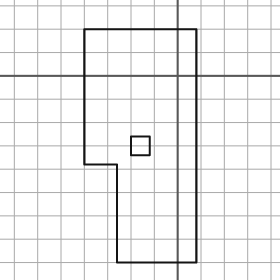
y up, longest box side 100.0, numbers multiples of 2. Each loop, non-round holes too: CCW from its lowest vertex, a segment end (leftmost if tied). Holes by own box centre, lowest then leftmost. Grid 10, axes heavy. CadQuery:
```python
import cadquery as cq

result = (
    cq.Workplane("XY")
    .moveTo(-26.0, -80.0)
    .lineTo(8.0, -80.0)
    .lineTo(8.0, 20.0)
    .lineTo(-40.0, 20.0)
    .lineTo(-40.0, -38.0)
    .lineTo(-26.0, -38.0)
    .close()
    .moveTo(-20.0, -34.0)
    .lineTo(-12.0, -34.0)
    .lineTo(-12.0, -26.0)
    .lineTo(-20.0, -26.0)
    .close()
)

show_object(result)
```